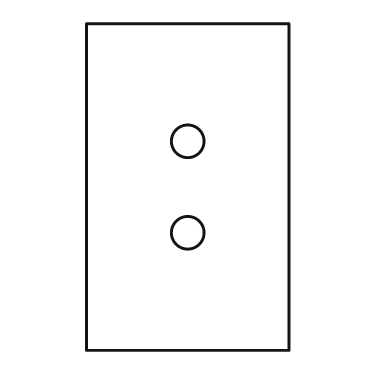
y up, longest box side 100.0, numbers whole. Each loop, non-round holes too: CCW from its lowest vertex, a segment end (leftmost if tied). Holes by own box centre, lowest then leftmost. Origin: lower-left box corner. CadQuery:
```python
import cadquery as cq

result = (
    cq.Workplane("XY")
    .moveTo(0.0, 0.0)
    .lineTo(62.0, 0.0)
    .lineTo(62.0, 100.0)
    .lineTo(0.0, 100.0)
    .close()
    .moveTo(31.0, 36.0)
    .circle(5.0)
    .moveTo(31.0, 64.0)
    .circle(5.0)
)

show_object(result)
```